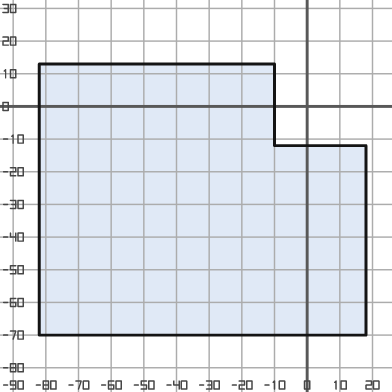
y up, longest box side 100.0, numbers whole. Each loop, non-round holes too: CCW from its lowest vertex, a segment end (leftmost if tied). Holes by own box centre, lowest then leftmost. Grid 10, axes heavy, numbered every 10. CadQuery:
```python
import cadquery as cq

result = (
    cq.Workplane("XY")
    .moveTo(-82.0, -70.0)
    .lineTo(18.0, -70.0)
    .lineTo(18.0, -12.0)
    .lineTo(-10.0, -12.0)
    .lineTo(-10.0, 13.0)
    .lineTo(-82.0, 13.0)
    .close()
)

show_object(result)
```